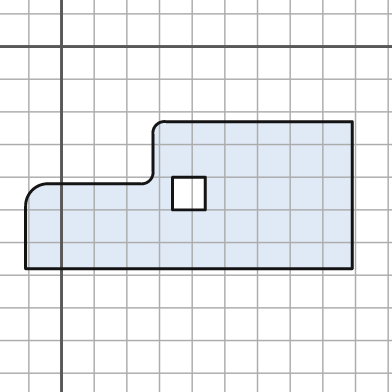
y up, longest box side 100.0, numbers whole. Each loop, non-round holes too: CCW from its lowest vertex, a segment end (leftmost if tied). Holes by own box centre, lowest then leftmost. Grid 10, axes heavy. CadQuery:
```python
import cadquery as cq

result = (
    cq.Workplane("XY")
    .moveTo(-11.0, -68.0)
    .lineTo(89.0, -68.0)
    .lineTo(89.0, -23.0)
    .lineTo(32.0, -23.0)
    .threePointArc((29.0, -24.0), (28.0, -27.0))
    .lineTo(28.0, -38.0)
    .threePointArc((27.0, -41.0), (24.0, -42.0))
    .lineTo(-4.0, -42.0)
    .threePointArc((-9.0, -44.0), (-11.0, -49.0))
    .close()
    .moveTo(34.0, -50.0)
    .lineTo(44.0, -50.0)
    .lineTo(44.0, -40.0)
    .lineTo(34.0, -40.0)
    .close()
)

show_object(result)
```